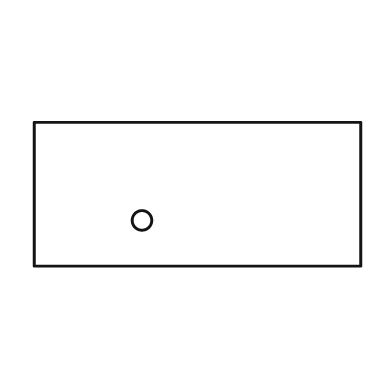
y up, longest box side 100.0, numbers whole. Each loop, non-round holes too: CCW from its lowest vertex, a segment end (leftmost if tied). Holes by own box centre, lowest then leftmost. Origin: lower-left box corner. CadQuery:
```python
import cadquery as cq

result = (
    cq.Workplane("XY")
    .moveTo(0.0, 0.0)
    .lineTo(100.0, 0.0)
    .lineTo(100.0, 44.0)
    .lineTo(0.0, 44.0)
    .close()
    .moveTo(33.0, 14.0)
    .circle(3.0)
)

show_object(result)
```